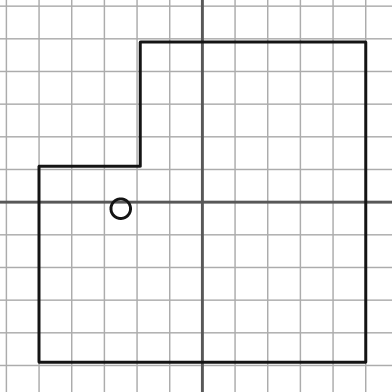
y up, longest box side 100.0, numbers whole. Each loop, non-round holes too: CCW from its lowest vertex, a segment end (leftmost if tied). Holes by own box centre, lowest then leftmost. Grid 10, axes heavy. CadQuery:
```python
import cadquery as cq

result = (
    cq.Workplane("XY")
    .moveTo(-50.0, -49.0)
    .lineTo(50.0, -49.0)
    .lineTo(50.0, 49.0)
    .lineTo(-19.0, 49.0)
    .lineTo(-19.0, 11.0)
    .lineTo(-50.0, 11.0)
    .close()
    .moveTo(-25.0, -2.0)
    .circle(3.0)
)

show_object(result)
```